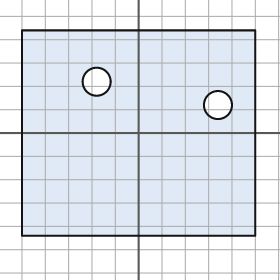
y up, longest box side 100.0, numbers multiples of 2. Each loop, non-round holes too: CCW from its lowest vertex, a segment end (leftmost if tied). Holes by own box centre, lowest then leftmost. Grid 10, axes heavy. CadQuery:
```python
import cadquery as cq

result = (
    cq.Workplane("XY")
    .moveTo(-50.0, -44.0)
    .lineTo(50.0, -44.0)
    .lineTo(50.0, 44.0)
    .lineTo(-50.0, 44.0)
    .close()
    .moveTo(34.0, 12.0)
    .circle(6.0)
    .moveTo(-18.0, 22.0)
    .circle(6.0)
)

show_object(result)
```